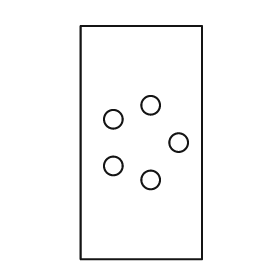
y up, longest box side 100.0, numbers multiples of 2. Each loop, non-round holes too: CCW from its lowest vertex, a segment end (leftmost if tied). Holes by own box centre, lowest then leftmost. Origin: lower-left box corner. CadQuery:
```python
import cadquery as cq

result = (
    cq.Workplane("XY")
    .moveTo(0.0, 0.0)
    .lineTo(52.0, 0.0)
    .lineTo(52.0, 100.0)
    .lineTo(0.0, 100.0)
    .close()
    .moveTo(30.0, 34.0)
    .circle(4.0)
    .moveTo(14.0, 40.0)
    .circle(4.0)
    .moveTo(42.0, 50.0)
    .circle(4.0)
    .moveTo(14.0, 60.0)
    .circle(4.0)
    .moveTo(30.0, 66.0)
    .circle(4.0)
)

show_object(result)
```